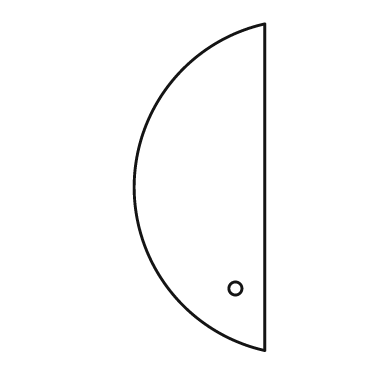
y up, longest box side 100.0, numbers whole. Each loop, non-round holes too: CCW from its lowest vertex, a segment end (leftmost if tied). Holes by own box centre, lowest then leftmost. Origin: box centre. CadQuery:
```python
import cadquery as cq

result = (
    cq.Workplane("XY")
    .moveTo(20.0, -50.0)
    .lineTo(20.0, 50.0)
    .threePointArc((-20.0, 0.0), (20.0, -50.0))
    .close()
    .moveTo(11.0, -31.0)
    .circle(2.0)
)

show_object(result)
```